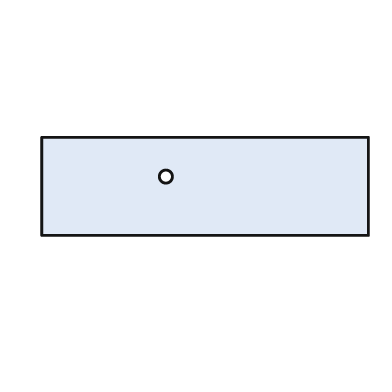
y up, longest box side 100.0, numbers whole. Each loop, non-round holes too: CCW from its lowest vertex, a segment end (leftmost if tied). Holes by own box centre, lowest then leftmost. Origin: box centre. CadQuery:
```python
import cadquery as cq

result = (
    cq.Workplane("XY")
    .moveTo(-50.0, -15.0)
    .lineTo(50.0, -15.0)
    .lineTo(50.0, 15.0)
    .lineTo(-50.0, 15.0)
    .close()
    .moveTo(-12.0, 3.0)
    .circle(2.0)
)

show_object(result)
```